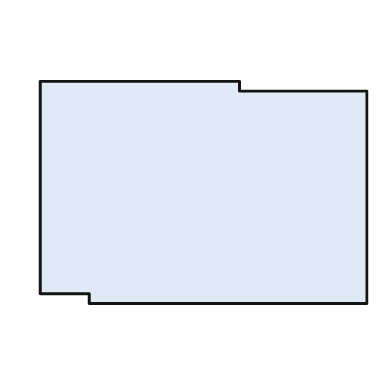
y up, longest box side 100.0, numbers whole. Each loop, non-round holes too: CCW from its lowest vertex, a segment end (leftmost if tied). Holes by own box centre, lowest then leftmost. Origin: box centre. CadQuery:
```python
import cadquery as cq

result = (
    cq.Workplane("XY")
    .moveTo(-35.0, -34.0)
    .lineTo(50.0, -34.0)
    .lineTo(50.0, 31.0)
    .lineTo(11.0, 31.0)
    .lineTo(11.0, 34.0)
    .lineTo(-50.0, 34.0)
    .lineTo(-50.0, -31.0)
    .lineTo(-35.0, -31.0)
    .close()
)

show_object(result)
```